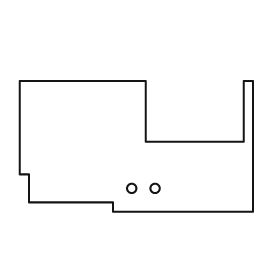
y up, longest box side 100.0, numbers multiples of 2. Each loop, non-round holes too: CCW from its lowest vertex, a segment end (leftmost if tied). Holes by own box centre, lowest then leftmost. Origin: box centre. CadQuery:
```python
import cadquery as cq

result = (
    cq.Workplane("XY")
    .moveTo(-10.0, -28.0)
    .lineTo(50.0, -28.0)
    .lineTo(50.0, 28.0)
    .lineTo(46.0, 28.0)
    .lineTo(46.0, 2.0)
    .lineTo(4.0, 2.0)
    .lineTo(4.0, 28.0)
    .lineTo(-50.0, 28.0)
    .lineTo(-50.0, -12.0)
    .lineTo(-46.0, -12.0)
    .lineTo(-46.0, -24.0)
    .lineTo(-10.0, -24.0)
    .close()
    .moveTo(-2.0, -18.0)
    .circle(2.0)
    .moveTo(8.0, -18.0)
    .circle(2.0)
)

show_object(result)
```